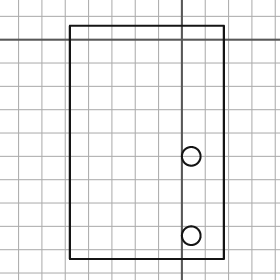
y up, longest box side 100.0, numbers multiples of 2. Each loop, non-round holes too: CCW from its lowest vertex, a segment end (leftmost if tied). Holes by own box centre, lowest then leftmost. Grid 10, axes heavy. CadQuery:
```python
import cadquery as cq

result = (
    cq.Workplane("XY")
    .moveTo(-48.0, -94.0)
    .lineTo(18.0, -94.0)
    .lineTo(18.0, 6.0)
    .lineTo(-48.0, 6.0)
    .close()
    .moveTo(4.0, -84.0)
    .circle(4.0)
    .moveTo(4.0, -50.0)
    .circle(4.0)
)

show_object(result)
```